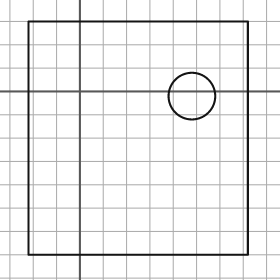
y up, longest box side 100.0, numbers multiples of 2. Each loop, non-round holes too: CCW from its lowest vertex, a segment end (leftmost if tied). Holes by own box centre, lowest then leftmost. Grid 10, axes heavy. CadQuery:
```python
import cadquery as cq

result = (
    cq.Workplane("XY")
    .moveTo(-22.0, -70.0)
    .lineTo(72.0, -70.0)
    .lineTo(72.0, 30.0)
    .lineTo(-22.0, 30.0)
    .close()
    .moveTo(48.0, -2.0)
    .circle(10.0)
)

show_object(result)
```